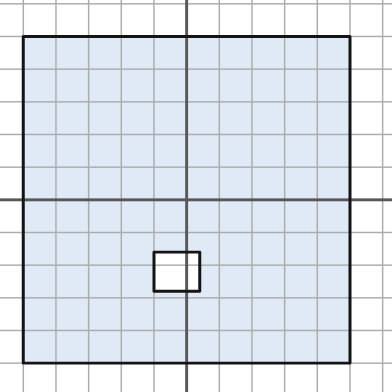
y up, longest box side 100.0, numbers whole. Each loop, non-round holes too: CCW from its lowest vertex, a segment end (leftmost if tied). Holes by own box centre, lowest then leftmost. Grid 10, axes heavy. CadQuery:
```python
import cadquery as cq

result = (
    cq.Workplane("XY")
    .moveTo(-50.0, -50.0)
    .lineTo(50.0, -50.0)
    .lineTo(50.0, 50.0)
    .lineTo(-50.0, 50.0)
    .close()
    .moveTo(-10.0, -28.0)
    .lineTo(4.0, -28.0)
    .lineTo(4.0, -16.0)
    .lineTo(-10.0, -16.0)
    .close()
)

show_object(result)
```